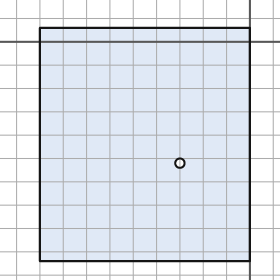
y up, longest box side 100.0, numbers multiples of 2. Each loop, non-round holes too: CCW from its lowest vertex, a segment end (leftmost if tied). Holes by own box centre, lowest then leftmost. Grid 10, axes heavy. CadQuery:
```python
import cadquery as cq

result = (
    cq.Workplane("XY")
    .moveTo(-90.0, -94.0)
    .lineTo(0.0, -94.0)
    .lineTo(0.0, 6.0)
    .lineTo(-90.0, 6.0)
    .close()
    .moveTo(-30.0, -52.0)
    .circle(2.0)
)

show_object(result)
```